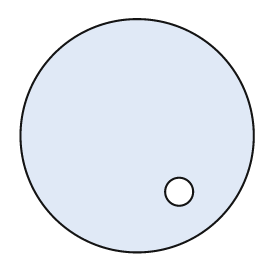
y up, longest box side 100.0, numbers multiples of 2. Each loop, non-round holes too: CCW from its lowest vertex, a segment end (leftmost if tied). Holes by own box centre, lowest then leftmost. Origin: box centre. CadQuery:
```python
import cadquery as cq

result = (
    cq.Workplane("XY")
    .moveTo(0.0, 0.0)
    .circle(50.0)
    .moveTo(18.0, -24.0)
    .circle(6.0)
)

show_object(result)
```